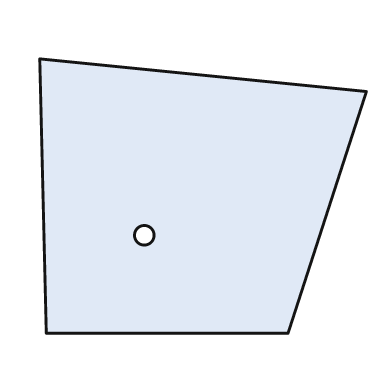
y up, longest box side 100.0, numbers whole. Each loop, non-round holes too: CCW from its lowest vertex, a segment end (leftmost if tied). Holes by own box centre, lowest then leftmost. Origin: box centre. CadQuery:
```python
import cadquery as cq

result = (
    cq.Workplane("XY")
    .moveTo(-48.0, -42.0)
    .lineTo(26.0, -42.0)
    .lineTo(50.0, 32.0)
    .lineTo(-50.0, 42.0)
    .close()
    .moveTo(-18.0, -12.0)
    .circle(3.0)
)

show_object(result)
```